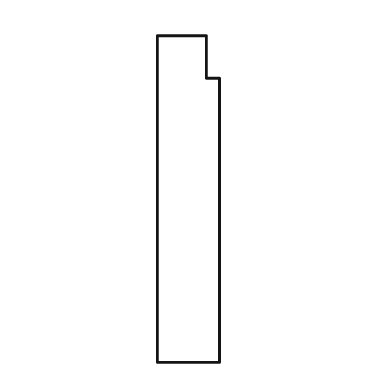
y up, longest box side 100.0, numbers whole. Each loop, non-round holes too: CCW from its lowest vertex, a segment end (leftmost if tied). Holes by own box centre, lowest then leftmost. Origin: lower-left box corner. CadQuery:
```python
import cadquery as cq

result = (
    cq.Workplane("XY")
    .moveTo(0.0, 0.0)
    .lineTo(19.0, 0.0)
    .lineTo(19.0, 87.0)
    .lineTo(15.0, 87.0)
    .lineTo(15.0, 100.0)
    .lineTo(0.0, 100.0)
    .close()
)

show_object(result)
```